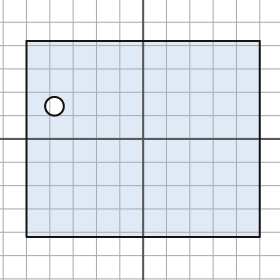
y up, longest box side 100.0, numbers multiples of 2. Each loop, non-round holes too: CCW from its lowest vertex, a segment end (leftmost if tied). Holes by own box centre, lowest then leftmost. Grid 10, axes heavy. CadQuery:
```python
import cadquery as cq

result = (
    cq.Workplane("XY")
    .moveTo(-50.0, -42.0)
    .lineTo(50.0, -42.0)
    .lineTo(50.0, 42.0)
    .lineTo(-50.0, 42.0)
    .close()
    .moveTo(-38.0, 14.0)
    .circle(4.0)
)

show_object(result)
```